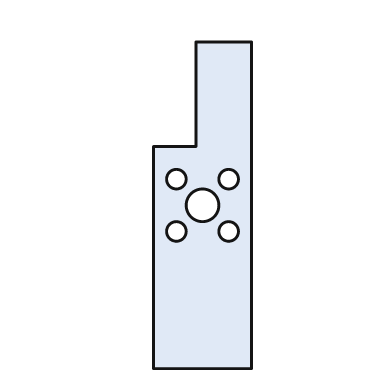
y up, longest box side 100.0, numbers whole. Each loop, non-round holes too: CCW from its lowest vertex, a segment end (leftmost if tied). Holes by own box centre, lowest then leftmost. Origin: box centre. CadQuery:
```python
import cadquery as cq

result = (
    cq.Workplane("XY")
    .moveTo(-15.0, -50.0)
    .lineTo(15.0, -50.0)
    .lineTo(15.0, 50.0)
    .lineTo(-2.0, 50.0)
    .lineTo(-2.0, 18.0)
    .lineTo(-15.0, 18.0)
    .close()
    .moveTo(-8.0, -8.0)
    .circle(3.0)
    .moveTo(8.0, -8.0)
    .circle(3.0)
    .moveTo(0.0, 0.0)
    .circle(5.0)
    .moveTo(-8.0, 8.0)
    .circle(3.0)
    .moveTo(8.0, 8.0)
    .circle(3.0)
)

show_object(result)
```